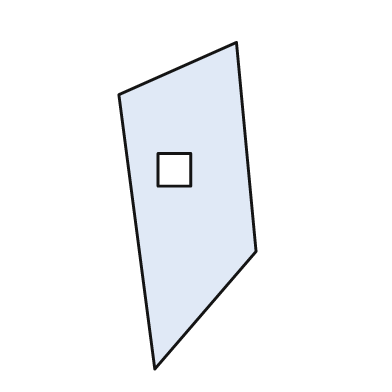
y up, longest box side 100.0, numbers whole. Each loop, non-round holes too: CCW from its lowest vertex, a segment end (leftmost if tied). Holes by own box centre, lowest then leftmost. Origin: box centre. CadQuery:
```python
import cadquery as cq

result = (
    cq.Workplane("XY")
    .moveTo(-10.0, -50.0)
    .lineTo(21.0, -14.0)
    .lineTo(15.0, 50.0)
    .lineTo(-21.0, 34.0)
    .close()
    .moveTo(-9.0, 6.0)
    .lineTo(1.0, 6.0)
    .lineTo(1.0, 16.0)
    .lineTo(-9.0, 16.0)
    .close()
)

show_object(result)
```